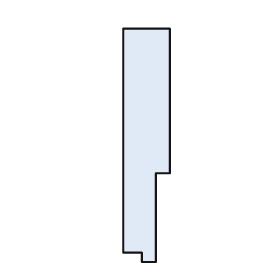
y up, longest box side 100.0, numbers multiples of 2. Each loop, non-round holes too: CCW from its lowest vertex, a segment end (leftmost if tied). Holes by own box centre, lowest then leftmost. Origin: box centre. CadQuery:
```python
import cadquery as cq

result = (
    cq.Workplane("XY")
    .moveTo(-2.0, -50.0)
    .lineTo(4.0, -50.0)
    .lineTo(4.0, -12.0)
    .lineTo(10.0, -12.0)
    .lineTo(10.0, 50.0)
    .lineTo(-10.0, 50.0)
    .lineTo(-10.0, -46.0)
    .lineTo(-2.0, -46.0)
    .close()
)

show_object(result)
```